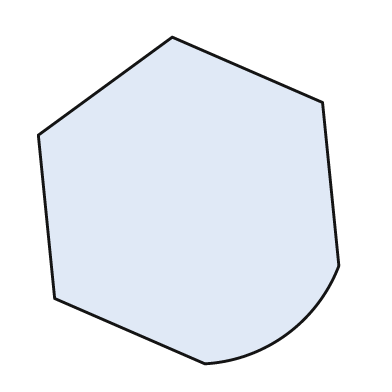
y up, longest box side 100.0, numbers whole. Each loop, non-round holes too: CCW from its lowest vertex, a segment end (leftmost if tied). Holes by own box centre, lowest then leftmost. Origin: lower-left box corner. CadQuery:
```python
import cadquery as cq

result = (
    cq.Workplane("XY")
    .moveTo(51.0, 0.0)
    .threePointArc((76.0, 9.0), (92.0, 30.0))
    .lineTo(87.0, 80.0)
    .lineTo(41.0, 100.0)
    .lineTo(0.0, 70.0)
    .lineTo(5.0, 20.0)
    .close()
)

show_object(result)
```